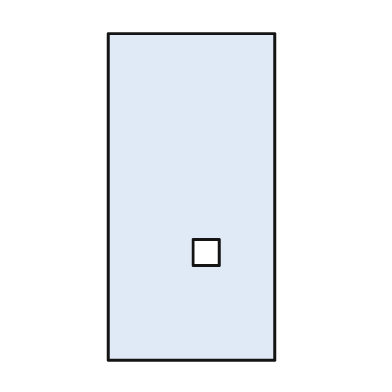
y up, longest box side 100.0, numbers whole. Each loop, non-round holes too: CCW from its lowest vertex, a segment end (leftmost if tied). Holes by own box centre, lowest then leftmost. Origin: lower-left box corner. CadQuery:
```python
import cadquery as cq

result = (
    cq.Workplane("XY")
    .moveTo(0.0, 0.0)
    .lineTo(51.0, 0.0)
    .lineTo(51.0, 100.0)
    .lineTo(0.0, 100.0)
    .close()
    .moveTo(26.0, 29.0)
    .lineTo(34.0, 29.0)
    .lineTo(34.0, 37.0)
    .lineTo(26.0, 37.0)
    .close()
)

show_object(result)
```